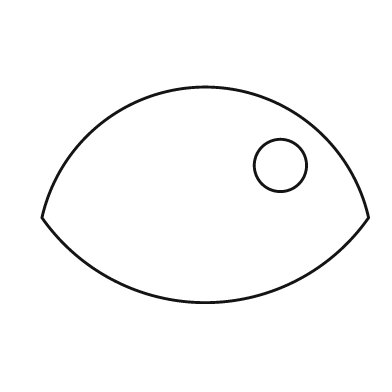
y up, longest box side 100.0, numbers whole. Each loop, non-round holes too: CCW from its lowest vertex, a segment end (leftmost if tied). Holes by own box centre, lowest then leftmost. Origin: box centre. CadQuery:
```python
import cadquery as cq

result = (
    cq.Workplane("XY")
    .moveTo(-50.0, -7.0)
    .threePointArc((0.0, -33.0), (50.0, -7.0))
    .threePointArc((0.0, 33.0), (-50.0, -7.0))
    .close()
    .moveTo(23.0, 9.0)
    .circle(8.0)
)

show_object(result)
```